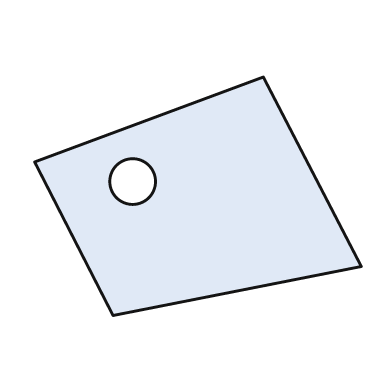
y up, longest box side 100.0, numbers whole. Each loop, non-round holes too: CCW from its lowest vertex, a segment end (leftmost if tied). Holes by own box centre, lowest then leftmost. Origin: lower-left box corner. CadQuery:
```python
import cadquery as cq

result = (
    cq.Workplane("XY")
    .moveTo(24.0, 0.0)
    .lineTo(100.0, 15.0)
    .lineTo(70.0, 73.0)
    .lineTo(0.0, 47.0)
    .close()
    .moveTo(30.0, 41.0)
    .circle(7.0)
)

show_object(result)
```